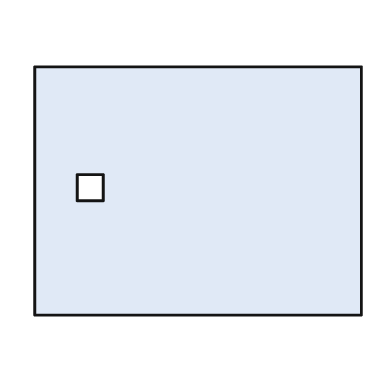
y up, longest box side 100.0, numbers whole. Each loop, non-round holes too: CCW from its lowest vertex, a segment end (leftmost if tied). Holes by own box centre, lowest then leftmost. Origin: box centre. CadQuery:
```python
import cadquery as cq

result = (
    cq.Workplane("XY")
    .moveTo(-50.0, -38.0)
    .lineTo(50.0, -38.0)
    .lineTo(50.0, 38.0)
    .lineTo(-50.0, 38.0)
    .close()
    .moveTo(-37.0, -3.0)
    .lineTo(-29.0, -3.0)
    .lineTo(-29.0, 5.0)
    .lineTo(-37.0, 5.0)
    .close()
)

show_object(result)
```